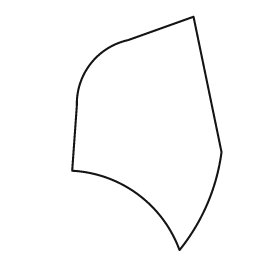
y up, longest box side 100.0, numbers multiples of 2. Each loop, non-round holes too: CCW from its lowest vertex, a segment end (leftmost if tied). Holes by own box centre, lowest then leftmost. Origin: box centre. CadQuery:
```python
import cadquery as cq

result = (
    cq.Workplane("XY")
    .moveTo(14.0, -50.0)
    .threePointArc((26.0, -30.0), (32.0, -8.0))
    .lineTo(20.0, 50.0)
    .lineTo(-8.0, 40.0)
    .threePointArc((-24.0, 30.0), (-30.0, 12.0))
    .lineTo(-32.0, -16.0)
    .threePointArc((-4.0, -26.0), (14.0, -50.0))
    .close()
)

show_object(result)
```